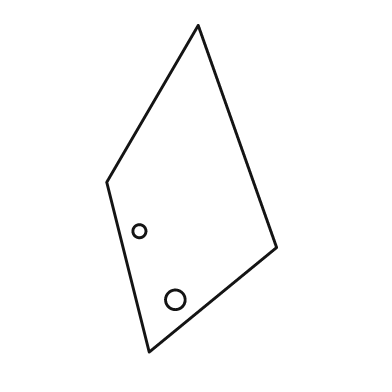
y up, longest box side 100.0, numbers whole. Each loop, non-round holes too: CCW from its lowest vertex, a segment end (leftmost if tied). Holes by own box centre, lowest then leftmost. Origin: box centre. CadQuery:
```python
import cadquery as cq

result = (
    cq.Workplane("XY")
    .moveTo(-13.0, -50.0)
    .lineTo(26.0, -18.0)
    .lineTo(2.0, 50.0)
    .lineTo(-26.0, 2.0)
    .close()
    .moveTo(-5.0, -34.0)
    .circle(3.0)
    .moveTo(-16.0, -13.0)
    .circle(2.0)
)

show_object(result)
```